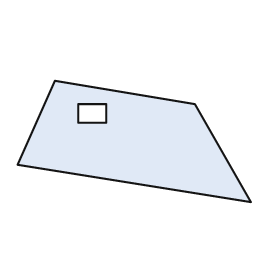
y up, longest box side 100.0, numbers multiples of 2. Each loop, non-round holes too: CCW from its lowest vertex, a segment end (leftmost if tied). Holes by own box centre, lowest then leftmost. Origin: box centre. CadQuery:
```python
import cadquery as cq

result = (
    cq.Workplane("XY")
    .moveTo(50.0, -26.0)
    .lineTo(26.0, 16.0)
    .lineTo(-34.0, 26.0)
    .lineTo(-50.0, -10.0)
    .close()
    .moveTo(-24.0, 8.0)
    .lineTo(-12.0, 8.0)
    .lineTo(-12.0, 16.0)
    .lineTo(-24.0, 16.0)
    .close()
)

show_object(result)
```